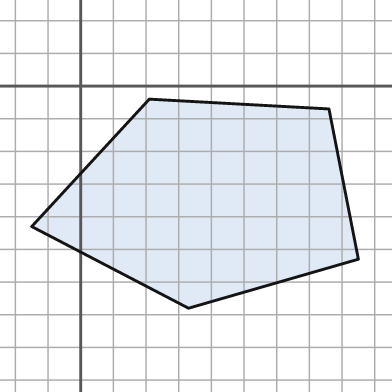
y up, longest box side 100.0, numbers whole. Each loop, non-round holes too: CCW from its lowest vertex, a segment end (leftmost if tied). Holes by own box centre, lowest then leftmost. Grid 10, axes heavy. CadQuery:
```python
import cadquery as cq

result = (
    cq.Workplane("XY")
    .moveTo(33.0, -68.0)
    .lineTo(85.0, -53.0)
    .lineTo(76.0, -7.0)
    .lineTo(21.0, -4.0)
    .lineTo(-15.0, -43.0)
    .close()
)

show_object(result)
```